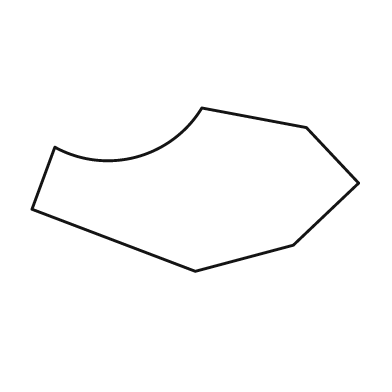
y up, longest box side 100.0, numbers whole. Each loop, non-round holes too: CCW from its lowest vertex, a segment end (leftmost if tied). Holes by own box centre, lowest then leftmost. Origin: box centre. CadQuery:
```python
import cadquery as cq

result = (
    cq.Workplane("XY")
    .moveTo(0.0, -25.0)
    .lineTo(30.0, -17.0)
    .lineTo(50.0, 2.0)
    .lineTo(34.0, 19.0)
    .lineTo(2.0, 25.0)
    .threePointArc((-18.0, 10.0), (-43.0, 13.0))
    .lineTo(-50.0, -6.0)
    .close()
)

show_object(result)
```